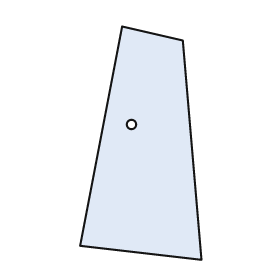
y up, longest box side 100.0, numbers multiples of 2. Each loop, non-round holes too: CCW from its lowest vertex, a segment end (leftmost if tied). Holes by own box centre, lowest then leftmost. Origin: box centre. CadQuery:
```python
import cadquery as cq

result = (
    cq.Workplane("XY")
    .moveTo(26.0, -50.0)
    .lineTo(18.0, 44.0)
    .lineTo(-8.0, 50.0)
    .lineTo(-26.0, -44.0)
    .close()
    .moveTo(-4.0, 8.0)
    .circle(2.0)
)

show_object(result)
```